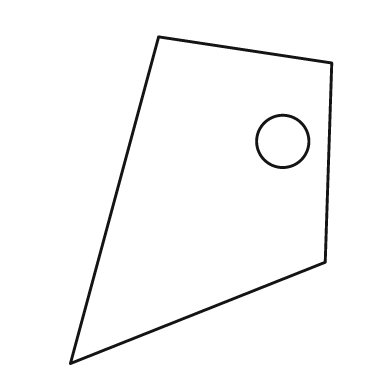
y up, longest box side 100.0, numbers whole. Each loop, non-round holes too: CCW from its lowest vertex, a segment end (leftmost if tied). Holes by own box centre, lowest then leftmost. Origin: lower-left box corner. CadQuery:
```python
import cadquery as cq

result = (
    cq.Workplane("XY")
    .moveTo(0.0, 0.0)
    .lineTo(78.0, 31.0)
    .lineTo(80.0, 92.0)
    .lineTo(27.0, 100.0)
    .close()
    .moveTo(65.0, 68.0)
    .circle(8.0)
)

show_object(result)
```